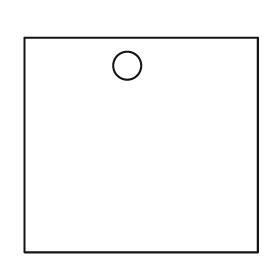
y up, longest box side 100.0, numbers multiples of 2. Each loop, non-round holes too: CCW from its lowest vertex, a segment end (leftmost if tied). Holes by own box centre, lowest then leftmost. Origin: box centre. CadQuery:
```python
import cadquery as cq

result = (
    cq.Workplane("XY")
    .moveTo(-50.0, -46.0)
    .lineTo(50.0, -46.0)
    .lineTo(50.0, 46.0)
    .lineTo(-50.0, 46.0)
    .close()
    .moveTo(-6.0, 34.0)
    .circle(6.0)
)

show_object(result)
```